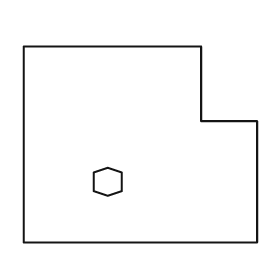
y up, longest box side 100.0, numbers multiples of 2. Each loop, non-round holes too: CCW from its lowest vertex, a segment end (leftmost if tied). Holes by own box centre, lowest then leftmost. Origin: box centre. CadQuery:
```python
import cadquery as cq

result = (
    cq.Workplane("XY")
    .moveTo(-50.0, -42.0)
    .lineTo(50.0, -42.0)
    .lineTo(50.0, 10.0)
    .lineTo(26.0, 10.0)
    .lineTo(26.0, 42.0)
    .lineTo(-50.0, 42.0)
    .close()
    .moveTo(-14.0, -22.0)
    .lineTo(-8.0, -20.0)
    .lineTo(-8.0, -12.0)
    .lineTo(-14.0, -10.0)
    .lineTo(-20.0, -12.0)
    .lineTo(-20.0, -20.0)
    .close()
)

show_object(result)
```